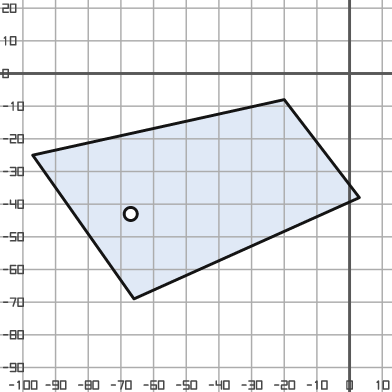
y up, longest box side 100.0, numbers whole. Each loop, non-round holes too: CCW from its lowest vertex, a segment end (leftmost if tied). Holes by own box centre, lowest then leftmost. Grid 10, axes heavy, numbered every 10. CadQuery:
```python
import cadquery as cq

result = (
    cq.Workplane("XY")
    .moveTo(-66.0, -69.0)
    .lineTo(3.0, -38.0)
    .lineTo(-20.0, -8.0)
    .lineTo(-97.0, -25.0)
    .close()
    .moveTo(-67.0, -43.0)
    .circle(2.0)
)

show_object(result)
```